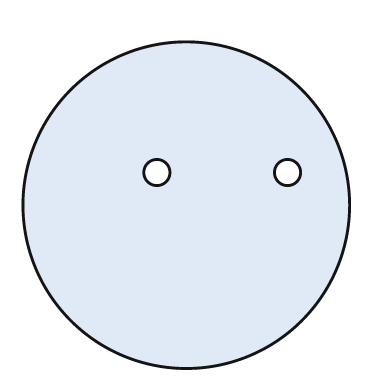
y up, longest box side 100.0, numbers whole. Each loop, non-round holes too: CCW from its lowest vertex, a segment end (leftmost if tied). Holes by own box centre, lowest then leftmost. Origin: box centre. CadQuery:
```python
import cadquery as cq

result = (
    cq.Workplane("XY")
    .moveTo(0.0, 0.0)
    .circle(50.0)
    .moveTo(-9.0, 10.0)
    .circle(4.0)
    .moveTo(31.0, 10.0)
    .circle(4.0)
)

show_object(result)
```